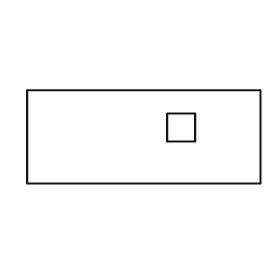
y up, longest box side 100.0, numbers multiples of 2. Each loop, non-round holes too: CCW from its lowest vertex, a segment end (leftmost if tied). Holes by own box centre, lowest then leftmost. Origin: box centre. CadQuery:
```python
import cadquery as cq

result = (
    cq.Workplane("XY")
    .moveTo(-50.0, -20.0)
    .lineTo(50.0, -20.0)
    .lineTo(50.0, 20.0)
    .lineTo(-50.0, 20.0)
    .close()
    .moveTo(10.0, -2.0)
    .lineTo(22.0, -2.0)
    .lineTo(22.0, 10.0)
    .lineTo(10.0, 10.0)
    .close()
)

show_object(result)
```